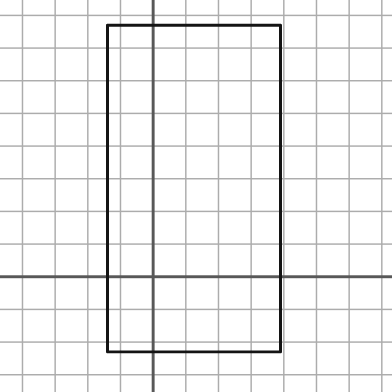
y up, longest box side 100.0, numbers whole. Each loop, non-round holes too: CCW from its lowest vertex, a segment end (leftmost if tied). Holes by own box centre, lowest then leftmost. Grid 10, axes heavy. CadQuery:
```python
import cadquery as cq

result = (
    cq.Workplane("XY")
    .moveTo(-14.0, -23.0)
    .lineTo(39.0, -23.0)
    .lineTo(39.0, 77.0)
    .lineTo(-14.0, 77.0)
    .close()
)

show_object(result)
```